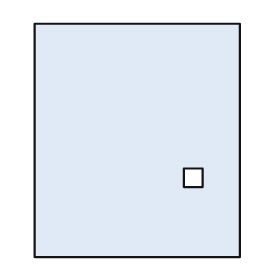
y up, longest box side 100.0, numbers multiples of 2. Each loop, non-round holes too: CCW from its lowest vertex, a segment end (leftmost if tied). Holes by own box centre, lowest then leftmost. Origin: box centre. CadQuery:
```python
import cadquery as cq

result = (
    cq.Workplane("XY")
    .moveTo(-44.0, -50.0)
    .lineTo(44.0, -50.0)
    .lineTo(44.0, 50.0)
    .lineTo(-44.0, 50.0)
    .close()
    .moveTo(20.0, -20.0)
    .lineTo(28.0, -20.0)
    .lineTo(28.0, -12.0)
    .lineTo(20.0, -12.0)
    .close()
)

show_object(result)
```